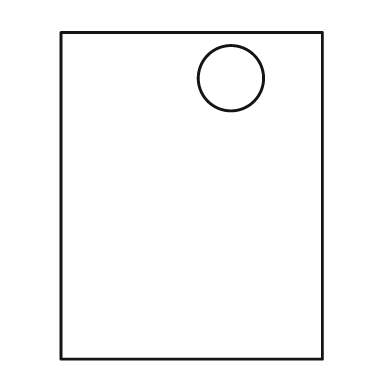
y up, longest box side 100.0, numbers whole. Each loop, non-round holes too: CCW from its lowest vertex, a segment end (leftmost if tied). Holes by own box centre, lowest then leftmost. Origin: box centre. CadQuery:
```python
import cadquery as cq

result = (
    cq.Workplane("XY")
    .moveTo(-40.0, -50.0)
    .lineTo(40.0, -50.0)
    .lineTo(40.0, 50.0)
    .lineTo(-40.0, 50.0)
    .close()
    .moveTo(12.0, 36.0)
    .circle(10.0)
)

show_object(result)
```